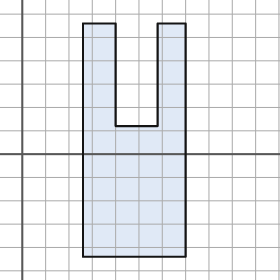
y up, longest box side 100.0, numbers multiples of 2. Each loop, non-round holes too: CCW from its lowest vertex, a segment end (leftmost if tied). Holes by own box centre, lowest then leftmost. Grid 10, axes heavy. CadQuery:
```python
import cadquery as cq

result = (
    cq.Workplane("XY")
    .moveTo(26.0, -44.0)
    .lineTo(70.0, -44.0)
    .lineTo(70.0, 56.0)
    .lineTo(58.0, 56.0)
    .lineTo(58.0, 12.0)
    .lineTo(40.0, 12.0)
    .lineTo(40.0, 56.0)
    .lineTo(26.0, 56.0)
    .close()
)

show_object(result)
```